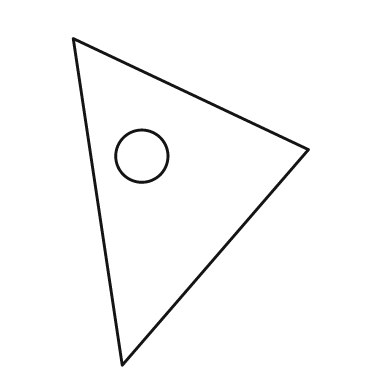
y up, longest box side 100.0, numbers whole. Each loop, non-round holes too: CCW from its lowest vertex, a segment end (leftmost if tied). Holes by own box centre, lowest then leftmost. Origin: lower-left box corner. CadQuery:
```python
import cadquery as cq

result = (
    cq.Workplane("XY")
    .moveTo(15.0, 0.0)
    .lineTo(72.0, 66.0)
    .lineTo(0.0, 100.0)
    .close()
    .moveTo(21.0, 64.0)
    .circle(8.0)
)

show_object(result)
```